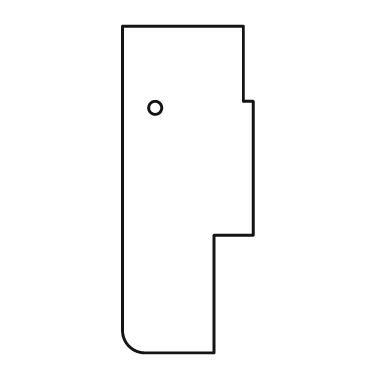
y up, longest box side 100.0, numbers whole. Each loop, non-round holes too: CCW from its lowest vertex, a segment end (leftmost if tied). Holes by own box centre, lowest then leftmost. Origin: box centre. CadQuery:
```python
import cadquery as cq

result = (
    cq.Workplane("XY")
    .moveTo(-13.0, -50.0)
    .lineTo(8.0, -50.0)
    .lineTo(8.0, -14.0)
    .lineTo(20.0, -14.0)
    .lineTo(20.0, 27.0)
    .lineTo(17.0, 27.0)
    .lineTo(17.0, 50.0)
    .lineTo(-20.0, 50.0)
    .lineTo(-20.0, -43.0)
    .threePointArc((-18.0, -48.0), (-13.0, -50.0))
    .close()
    .moveTo(-10.0, 25.0)
    .circle(2.0)
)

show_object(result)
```